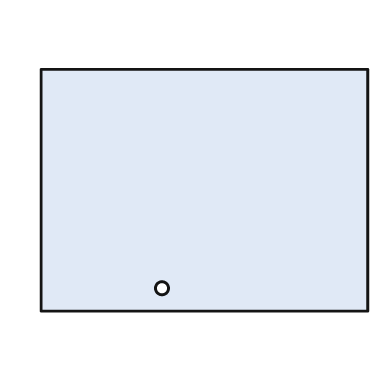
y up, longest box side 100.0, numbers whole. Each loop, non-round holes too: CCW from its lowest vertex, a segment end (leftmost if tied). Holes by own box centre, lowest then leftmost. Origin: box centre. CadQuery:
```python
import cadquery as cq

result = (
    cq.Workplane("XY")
    .moveTo(-50.0, -37.0)
    .lineTo(50.0, -37.0)
    .lineTo(50.0, 37.0)
    .lineTo(-50.0, 37.0)
    .close()
    .moveTo(-13.0, -30.0)
    .circle(2.0)
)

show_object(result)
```